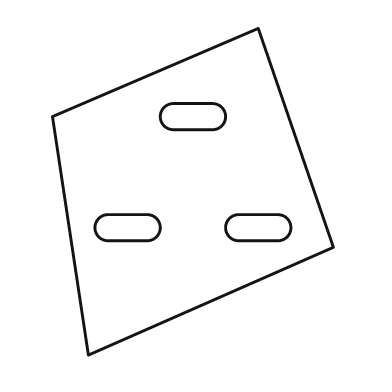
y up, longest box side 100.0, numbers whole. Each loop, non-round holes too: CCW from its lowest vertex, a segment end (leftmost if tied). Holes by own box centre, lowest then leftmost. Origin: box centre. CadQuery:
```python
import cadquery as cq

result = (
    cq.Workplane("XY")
    .moveTo(-32.0, -50.0)
    .lineTo(43.0, -17.0)
    .lineTo(20.0, 50.0)
    .lineTo(-43.0, 23.0)
    .close()
    .moveTo(-26.0, -15.0)
    .lineTo(-14.0, -15.0)
    .threePointArc((-10.0, -11.0), (-14.0, -7.0))
    .lineTo(-26.0, -7.0)
    .threePointArc((-30.0, -11.0), (-26.0, -15.0))
    .close()
    .moveTo(14.0, -15.0)
    .lineTo(26.0, -15.0)
    .threePointArc((30.0, -11.0), (26.0, -7.0))
    .lineTo(14.0, -7.0)
    .threePointArc((10.0, -11.0), (14.0, -15.0))
    .close()
    .moveTo(-6.0, 19.0)
    .lineTo(6.0, 19.0)
    .threePointArc((10.0, 23.0), (6.0, 27.0))
    .lineTo(-6.0, 27.0)
    .threePointArc((-10.0, 23.0), (-6.0, 19.0))
    .close()
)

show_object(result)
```